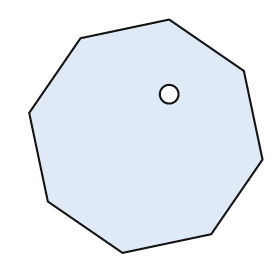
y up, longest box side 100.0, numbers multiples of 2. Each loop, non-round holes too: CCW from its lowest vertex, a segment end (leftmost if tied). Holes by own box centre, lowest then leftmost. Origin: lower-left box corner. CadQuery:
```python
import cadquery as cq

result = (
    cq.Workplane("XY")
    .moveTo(40.0, 0.0)
    .lineTo(78.0, 8.0)
    .lineTo(100.0, 40.0)
    .lineTo(92.0, 78.0)
    .lineTo(60.0, 100.0)
    .lineTo(22.0, 92.0)
    .lineTo(0.0, 60.0)
    .lineTo(8.0, 22.0)
    .close()
    .moveTo(60.0, 68.0)
    .circle(4.0)
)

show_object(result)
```